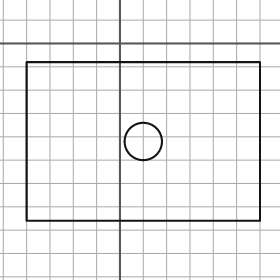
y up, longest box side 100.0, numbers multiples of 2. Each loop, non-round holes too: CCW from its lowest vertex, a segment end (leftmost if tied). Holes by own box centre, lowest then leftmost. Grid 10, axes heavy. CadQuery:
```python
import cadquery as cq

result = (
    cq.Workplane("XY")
    .moveTo(-40.0, -76.0)
    .lineTo(60.0, -76.0)
    .lineTo(60.0, -8.0)
    .lineTo(-40.0, -8.0)
    .close()
    .moveTo(10.0, -42.0)
    .circle(8.0)
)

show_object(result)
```